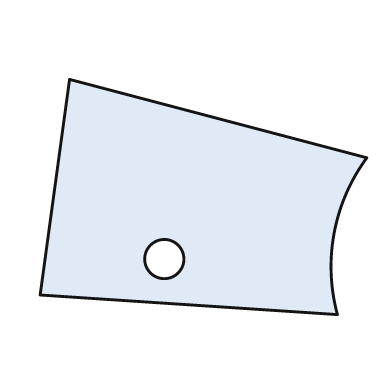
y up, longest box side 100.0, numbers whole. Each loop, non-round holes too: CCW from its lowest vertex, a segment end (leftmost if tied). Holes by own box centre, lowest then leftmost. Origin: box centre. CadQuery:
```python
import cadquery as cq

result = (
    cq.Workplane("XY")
    .moveTo(41.0, -36.0)
    .threePointArc((40.0, -11.0), (50.0, 12.0))
    .lineTo(-41.0, 36.0)
    .lineTo(-50.0, -30.0)
    .close()
    .moveTo(-12.0, -19.0)
    .circle(6.0)
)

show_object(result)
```